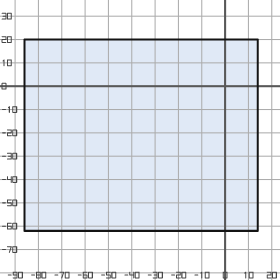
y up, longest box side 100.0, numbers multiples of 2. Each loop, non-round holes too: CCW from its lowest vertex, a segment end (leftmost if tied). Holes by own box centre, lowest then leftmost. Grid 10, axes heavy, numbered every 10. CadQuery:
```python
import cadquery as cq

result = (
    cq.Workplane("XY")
    .moveTo(-86.0, -62.0)
    .lineTo(14.0, -62.0)
    .lineTo(14.0, 20.0)
    .lineTo(-86.0, 20.0)
    .close()
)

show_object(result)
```